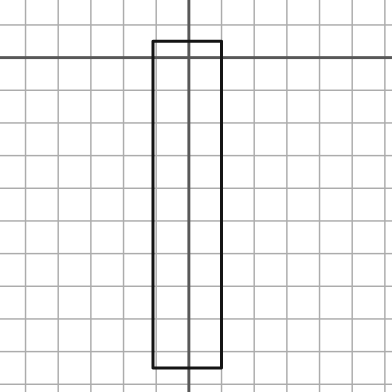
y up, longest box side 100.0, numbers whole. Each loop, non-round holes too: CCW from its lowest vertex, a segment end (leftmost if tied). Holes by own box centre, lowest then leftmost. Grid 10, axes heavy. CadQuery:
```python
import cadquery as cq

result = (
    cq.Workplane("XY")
    .moveTo(-11.0, -95.0)
    .lineTo(10.0, -95.0)
    .lineTo(10.0, 5.0)
    .lineTo(-11.0, 5.0)
    .close()
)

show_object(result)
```